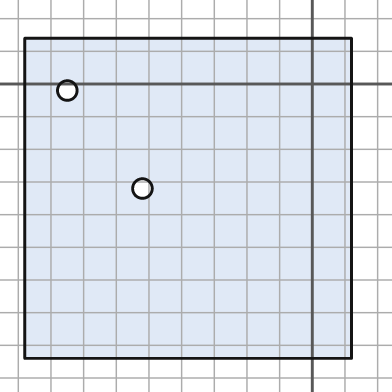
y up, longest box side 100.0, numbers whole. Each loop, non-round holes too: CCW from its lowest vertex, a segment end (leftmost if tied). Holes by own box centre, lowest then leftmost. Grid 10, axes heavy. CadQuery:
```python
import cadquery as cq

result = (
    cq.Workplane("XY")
    .moveTo(-88.0, -84.0)
    .lineTo(12.0, -84.0)
    .lineTo(12.0, 14.0)
    .lineTo(-88.0, 14.0)
    .close()
    .moveTo(-52.0, -32.0)
    .circle(3.0)
    .moveTo(-75.0, -2.0)
    .circle(3.0)
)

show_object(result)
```